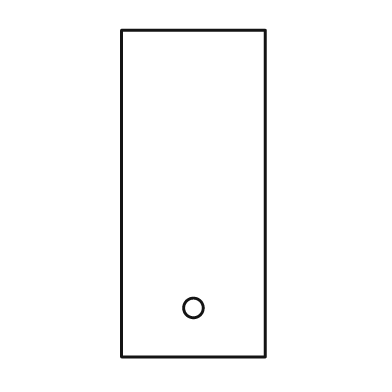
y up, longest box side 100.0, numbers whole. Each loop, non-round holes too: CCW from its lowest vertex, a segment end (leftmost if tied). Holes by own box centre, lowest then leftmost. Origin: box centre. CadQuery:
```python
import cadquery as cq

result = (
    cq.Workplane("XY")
    .moveTo(-22.0, -50.0)
    .lineTo(22.0, -50.0)
    .lineTo(22.0, 50.0)
    .lineTo(-22.0, 50.0)
    .close()
    .moveTo(0.0, -35.0)
    .circle(3.0)
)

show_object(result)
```